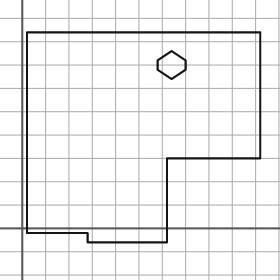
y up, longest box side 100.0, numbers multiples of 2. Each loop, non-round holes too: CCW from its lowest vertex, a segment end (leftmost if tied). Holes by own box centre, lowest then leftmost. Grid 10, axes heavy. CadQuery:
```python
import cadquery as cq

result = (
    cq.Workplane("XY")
    .moveTo(28.0, -6.0)
    .lineTo(62.0, -6.0)
    .lineTo(62.0, 30.0)
    .lineTo(102.0, 30.0)
    .lineTo(102.0, 84.0)
    .lineTo(2.0, 84.0)
    .lineTo(2.0, -2.0)
    .lineTo(28.0, -2.0)
    .close()
    .moveTo(64.0, 64.0)
    .lineTo(70.0, 68.0)
    .lineTo(70.0, 72.0)
    .lineTo(64.0, 76.0)
    .lineTo(58.0, 72.0)
    .lineTo(58.0, 68.0)
    .close()
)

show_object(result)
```